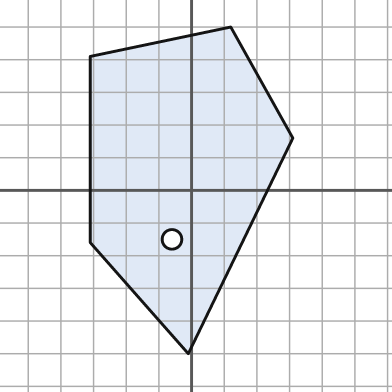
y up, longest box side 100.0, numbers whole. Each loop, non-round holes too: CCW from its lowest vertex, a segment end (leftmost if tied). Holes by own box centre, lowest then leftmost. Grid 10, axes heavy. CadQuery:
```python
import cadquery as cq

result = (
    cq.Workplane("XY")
    .moveTo(-1.0, -50.0)
    .lineTo(31.0, 16.0)
    .lineTo(12.0, 50.0)
    .lineTo(-31.0, 41.0)
    .lineTo(-31.0, -16.0)
    .close()
    .moveTo(-6.0, -15.0)
    .circle(3.0)
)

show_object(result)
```